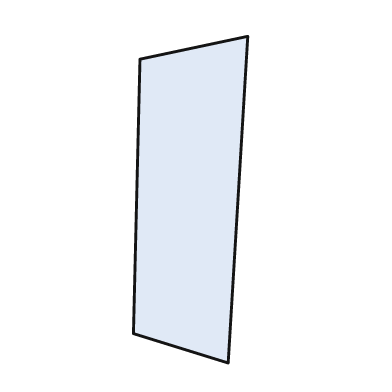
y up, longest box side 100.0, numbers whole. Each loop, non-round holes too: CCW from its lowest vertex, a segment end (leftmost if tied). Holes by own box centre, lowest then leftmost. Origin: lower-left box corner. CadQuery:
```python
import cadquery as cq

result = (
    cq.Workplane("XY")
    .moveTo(29.0, 0.0)
    .lineTo(35.0, 100.0)
    .lineTo(2.0, 93.0)
    .lineTo(0.0, 9.0)
    .close()
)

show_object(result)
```